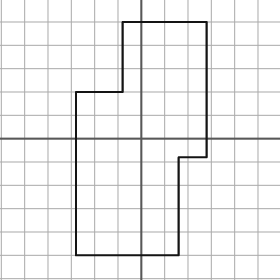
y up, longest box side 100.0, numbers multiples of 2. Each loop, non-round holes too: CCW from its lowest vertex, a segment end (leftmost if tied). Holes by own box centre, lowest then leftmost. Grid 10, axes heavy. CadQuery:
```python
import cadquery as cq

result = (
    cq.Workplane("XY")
    .moveTo(-28.0, -50.0)
    .lineTo(16.0, -50.0)
    .lineTo(16.0, -8.0)
    .lineTo(28.0, -8.0)
    .lineTo(28.0, 50.0)
    .lineTo(-8.0, 50.0)
    .lineTo(-8.0, 20.0)
    .lineTo(-28.0, 20.0)
    .close()
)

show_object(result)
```